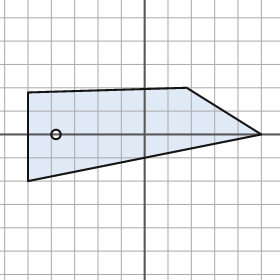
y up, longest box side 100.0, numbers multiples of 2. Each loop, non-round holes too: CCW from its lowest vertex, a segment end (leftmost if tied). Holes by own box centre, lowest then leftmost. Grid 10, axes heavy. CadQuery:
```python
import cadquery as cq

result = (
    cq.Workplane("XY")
    .moveTo(-50.0, -20.0)
    .lineTo(50.0, 0.0)
    .lineTo(18.0, 20.0)
    .lineTo(-50.0, 18.0)
    .close()
    .moveTo(-38.0, 0.0)
    .circle(2.0)
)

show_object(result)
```